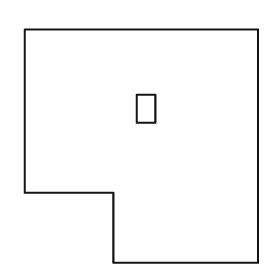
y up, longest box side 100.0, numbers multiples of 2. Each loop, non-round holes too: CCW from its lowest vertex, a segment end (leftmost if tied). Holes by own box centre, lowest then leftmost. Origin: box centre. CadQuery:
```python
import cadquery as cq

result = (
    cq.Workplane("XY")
    .moveTo(-12.0, -50.0)
    .lineTo(50.0, -50.0)
    .lineTo(50.0, 50.0)
    .lineTo(-50.0, 50.0)
    .lineTo(-50.0, -20.0)
    .lineTo(-12.0, -20.0)
    .close()
    .moveTo(-2.0, 10.0)
    .lineTo(6.0, 10.0)
    .lineTo(6.0, 22.0)
    .lineTo(-2.0, 22.0)
    .close()
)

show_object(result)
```